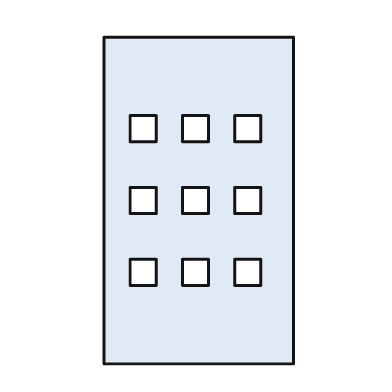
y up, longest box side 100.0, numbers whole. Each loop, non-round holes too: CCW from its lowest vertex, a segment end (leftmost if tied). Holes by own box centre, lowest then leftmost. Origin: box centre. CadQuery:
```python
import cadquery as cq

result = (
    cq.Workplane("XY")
    .moveTo(-29.0, -50.0)
    .lineTo(29.0, -50.0)
    .lineTo(29.0, 50.0)
    .lineTo(-29.0, 50.0)
    .close()
    .moveTo(-21.0, -26.0)
    .lineTo(-13.0, -26.0)
    .lineTo(-13.0, -18.0)
    .lineTo(-21.0, -18.0)
    .close()
    .moveTo(-5.0, -26.0)
    .lineTo(3.0, -26.0)
    .lineTo(3.0, -18.0)
    .lineTo(-5.0, -18.0)
    .close()
    .moveTo(11.0, -26.0)
    .lineTo(19.0, -26.0)
    .lineTo(19.0, -18.0)
    .lineTo(11.0, -18.0)
    .close()
    .moveTo(-21.0, -4.0)
    .lineTo(-13.0, -4.0)
    .lineTo(-13.0, 4.0)
    .lineTo(-21.0, 4.0)
    .close()
    .moveTo(-5.0, -4.0)
    .lineTo(3.0, -4.0)
    .lineTo(3.0, 4.0)
    .lineTo(-5.0, 4.0)
    .close()
    .moveTo(11.0, -4.0)
    .lineTo(19.0, -4.0)
    .lineTo(19.0, 4.0)
    .lineTo(11.0, 4.0)
    .close()
    .moveTo(-21.0, 18.0)
    .lineTo(-13.0, 18.0)
    .lineTo(-13.0, 26.0)
    .lineTo(-21.0, 26.0)
    .close()
    .moveTo(-5.0, 18.0)
    .lineTo(3.0, 18.0)
    .lineTo(3.0, 26.0)
    .lineTo(-5.0, 26.0)
    .close()
    .moveTo(11.0, 18.0)
    .lineTo(19.0, 18.0)
    .lineTo(19.0, 26.0)
    .lineTo(11.0, 26.0)
    .close()
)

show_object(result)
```